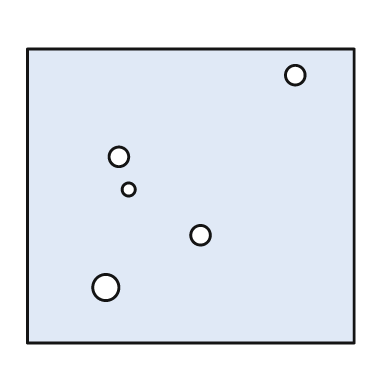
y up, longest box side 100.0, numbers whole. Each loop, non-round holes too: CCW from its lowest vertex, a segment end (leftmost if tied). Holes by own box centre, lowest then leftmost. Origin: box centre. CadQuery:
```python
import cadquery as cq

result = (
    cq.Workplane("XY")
    .moveTo(-50.0, -45.0)
    .lineTo(50.0, -45.0)
    .lineTo(50.0, 45.0)
    .lineTo(-50.0, 45.0)
    .close()
    .moveTo(-26.0, -28.0)
    .circle(4.0)
    .moveTo(3.0, -12.0)
    .circle(3.0)
    .moveTo(-19.0, 2.0)
    .circle(2.0)
    .moveTo(-22.0, 12.0)
    .circle(3.0)
    .moveTo(32.0, 37.0)
    .circle(3.0)
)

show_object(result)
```